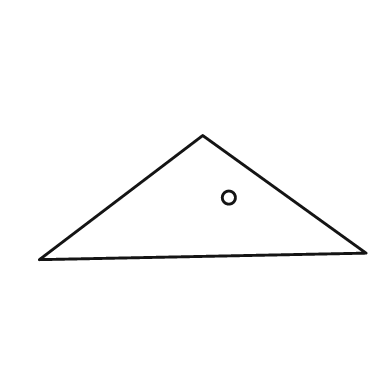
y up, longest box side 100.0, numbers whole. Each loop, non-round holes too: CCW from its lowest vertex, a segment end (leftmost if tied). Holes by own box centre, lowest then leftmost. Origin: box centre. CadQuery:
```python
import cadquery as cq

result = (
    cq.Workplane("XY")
    .moveTo(-50.0, -19.0)
    .lineTo(50.0, -17.0)
    .lineTo(0.0, 19.0)
    .close()
    .moveTo(8.0, 0.0)
    .circle(2.0)
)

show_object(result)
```